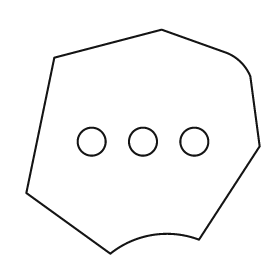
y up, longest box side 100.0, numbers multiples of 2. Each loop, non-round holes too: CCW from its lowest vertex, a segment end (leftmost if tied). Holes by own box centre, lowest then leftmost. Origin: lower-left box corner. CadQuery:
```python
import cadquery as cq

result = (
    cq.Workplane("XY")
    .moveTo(36.0, 0.0)
    .threePointArc((54.0, 8.0), (74.0, 6.0))
    .lineTo(100.0, 46.0)
    .lineTo(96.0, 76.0)
    .threePointArc((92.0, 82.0), (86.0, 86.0))
    .lineTo(58.0, 96.0)
    .lineTo(12.0, 84.0)
    .lineTo(0.0, 26.0)
    .close()
    .moveTo(28.0, 48.0)
    .circle(6.0)
    .moveTo(50.0, 48.0)
    .circle(6.0)
    .moveTo(72.0, 48.0)
    .circle(6.0)
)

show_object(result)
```